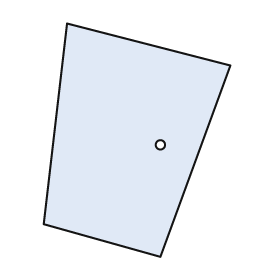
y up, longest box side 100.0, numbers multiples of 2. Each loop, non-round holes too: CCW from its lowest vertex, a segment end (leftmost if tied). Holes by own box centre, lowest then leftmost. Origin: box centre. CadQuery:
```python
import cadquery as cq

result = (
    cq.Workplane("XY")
    .moveTo(10.0, -50.0)
    .lineTo(40.0, 32.0)
    .lineTo(-30.0, 50.0)
    .lineTo(-40.0, -36.0)
    .close()
    .moveTo(10.0, -2.0)
    .circle(2.0)
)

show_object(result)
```